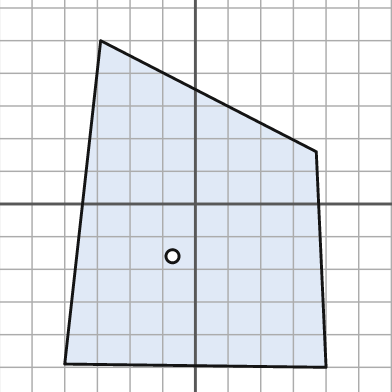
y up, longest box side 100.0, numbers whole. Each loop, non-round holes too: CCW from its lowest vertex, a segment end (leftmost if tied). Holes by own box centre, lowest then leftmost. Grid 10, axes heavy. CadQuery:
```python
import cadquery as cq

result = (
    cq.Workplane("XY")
    .moveTo(40.0, -50.0)
    .lineTo(37.0, 16.0)
    .lineTo(-29.0, 50.0)
    .lineTo(-40.0, -49.0)
    .close()
    .moveTo(-7.0, -16.0)
    .circle(2.0)
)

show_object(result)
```